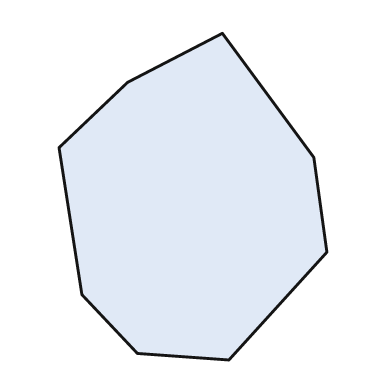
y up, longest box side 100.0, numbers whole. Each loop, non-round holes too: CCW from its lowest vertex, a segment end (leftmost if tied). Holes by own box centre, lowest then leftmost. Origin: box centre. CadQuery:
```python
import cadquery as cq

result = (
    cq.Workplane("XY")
    .moveTo(11.0, -50.0)
    .lineTo(41.0, -17.0)
    .lineTo(37.0, 12.0)
    .lineTo(9.0, 50.0)
    .lineTo(-20.0, 35.0)
    .lineTo(-41.0, 15.0)
    .lineTo(-34.0, -30.0)
    .lineTo(-17.0, -48.0)
    .close()
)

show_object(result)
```